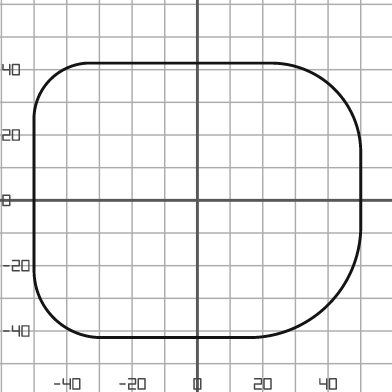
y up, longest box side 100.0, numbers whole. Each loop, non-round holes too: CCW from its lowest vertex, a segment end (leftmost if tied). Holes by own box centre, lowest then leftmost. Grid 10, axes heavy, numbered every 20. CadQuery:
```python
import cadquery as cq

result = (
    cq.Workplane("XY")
    .moveTo(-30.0, -42.0)
    .lineTo(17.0, -42.0)
    .threePointArc((40.0, -32.0), (50.0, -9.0))
    .lineTo(50.0, 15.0)
    .threePointArc((42.0, 34.0), (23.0, 42.0))
    .lineTo(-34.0, 42.0)
    .threePointArc((-45.0, 37.0), (-50.0, 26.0))
    .lineTo(-50.0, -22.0)
    .threePointArc((-44.0, -36.0), (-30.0, -42.0))
    .close()
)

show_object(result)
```